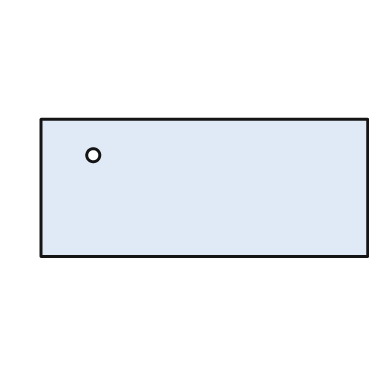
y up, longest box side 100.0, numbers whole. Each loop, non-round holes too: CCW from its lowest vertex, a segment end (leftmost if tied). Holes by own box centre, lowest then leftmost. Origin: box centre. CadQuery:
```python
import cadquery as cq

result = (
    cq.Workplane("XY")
    .moveTo(-50.0, -21.0)
    .lineTo(50.0, -21.0)
    .lineTo(50.0, 21.0)
    .lineTo(-50.0, 21.0)
    .close()
    .moveTo(-34.0, 10.0)
    .circle(2.0)
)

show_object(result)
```